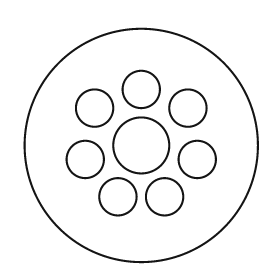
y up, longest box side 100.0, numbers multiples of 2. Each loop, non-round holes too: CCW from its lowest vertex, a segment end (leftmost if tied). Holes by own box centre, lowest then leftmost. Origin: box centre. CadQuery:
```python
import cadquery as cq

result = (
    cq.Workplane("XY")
    .moveTo(0.0, 0.0)
    .circle(50.0)
    .moveTo(-10.0, -22.0)
    .circle(8.0)
    .moveTo(10.0, -22.0)
    .circle(8.0)
    .moveTo(-24.0, -6.0)
    .circle(8.0)
    .moveTo(24.0, -6.0)
    .circle(8.0)
    .moveTo(0.0, 0.0)
    .circle(12.0)
    .moveTo(-20.0, 16.0)
    .circle(8.0)
    .moveTo(20.0, 16.0)
    .circle(8.0)
    .moveTo(0.0, 24.0)
    .circle(8.0)
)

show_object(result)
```